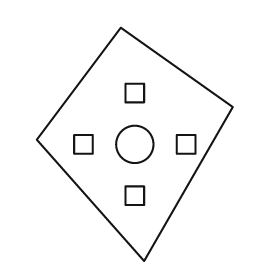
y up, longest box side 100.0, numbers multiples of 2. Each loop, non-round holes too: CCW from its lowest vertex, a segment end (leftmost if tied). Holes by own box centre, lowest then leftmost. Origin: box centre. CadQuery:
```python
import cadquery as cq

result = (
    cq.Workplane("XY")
    .moveTo(4.0, -50.0)
    .lineTo(42.0, 16.0)
    .lineTo(-6.0, 50.0)
    .lineTo(-42.0, 2.0)
    .close()
    .moveTo(-4.0, -26.0)
    .lineTo(4.0, -26.0)
    .lineTo(4.0, -18.0)
    .lineTo(-4.0, -18.0)
    .close()
    .moveTo(-26.0, -4.0)
    .lineTo(-18.0, -4.0)
    .lineTo(-18.0, 4.0)
    .lineTo(-26.0, 4.0)
    .close()
    .moveTo(0.0, 0.0)
    .circle(8.0)
    .moveTo(18.0, -4.0)
    .lineTo(26.0, -4.0)
    .lineTo(26.0, 4.0)
    .lineTo(18.0, 4.0)
    .close()
    .moveTo(-4.0, 18.0)
    .lineTo(4.0, 18.0)
    .lineTo(4.0, 26.0)
    .lineTo(-4.0, 26.0)
    .close()
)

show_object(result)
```